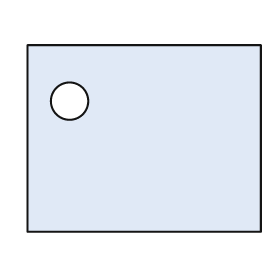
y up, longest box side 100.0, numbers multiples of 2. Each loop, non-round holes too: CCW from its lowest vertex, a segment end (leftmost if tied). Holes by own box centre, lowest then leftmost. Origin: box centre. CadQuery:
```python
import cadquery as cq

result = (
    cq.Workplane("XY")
    .moveTo(-50.0, -40.0)
    .lineTo(50.0, -40.0)
    .lineTo(50.0, 40.0)
    .lineTo(-50.0, 40.0)
    .close()
    .moveTo(-32.0, 16.0)
    .circle(8.0)
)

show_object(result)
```